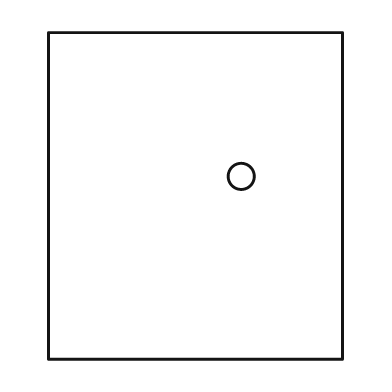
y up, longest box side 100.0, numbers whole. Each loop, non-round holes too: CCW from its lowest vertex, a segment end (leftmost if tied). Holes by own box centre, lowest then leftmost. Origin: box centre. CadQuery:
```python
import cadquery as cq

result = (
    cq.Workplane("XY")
    .moveTo(-45.0, -50.0)
    .lineTo(45.0, -50.0)
    .lineTo(45.0, 50.0)
    .lineTo(-45.0, 50.0)
    .close()
    .moveTo(14.0, 6.0)
    .circle(4.0)
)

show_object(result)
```